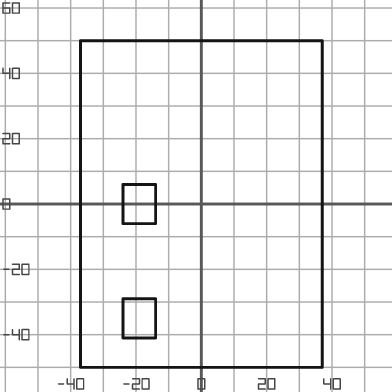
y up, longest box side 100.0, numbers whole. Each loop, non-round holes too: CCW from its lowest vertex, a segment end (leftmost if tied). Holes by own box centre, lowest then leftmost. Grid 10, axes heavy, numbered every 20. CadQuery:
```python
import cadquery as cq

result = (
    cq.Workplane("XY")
    .moveTo(-37.0, -50.0)
    .lineTo(37.0, -50.0)
    .lineTo(37.0, 50.0)
    .lineTo(-37.0, 50.0)
    .close()
    .moveTo(-24.0, -41.0)
    .lineTo(-14.0, -41.0)
    .lineTo(-14.0, -29.0)
    .lineTo(-24.0, -29.0)
    .close()
    .moveTo(-24.0, -6.0)
    .lineTo(-14.0, -6.0)
    .lineTo(-14.0, 6.0)
    .lineTo(-24.0, 6.0)
    .close()
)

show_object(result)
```